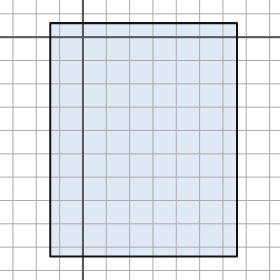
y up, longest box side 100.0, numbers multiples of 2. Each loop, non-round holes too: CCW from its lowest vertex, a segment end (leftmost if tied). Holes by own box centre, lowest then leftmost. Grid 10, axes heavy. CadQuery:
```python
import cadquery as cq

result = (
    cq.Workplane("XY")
    .moveTo(-14.0, -94.0)
    .lineTo(66.0, -94.0)
    .lineTo(66.0, 6.0)
    .lineTo(-14.0, 6.0)
    .close()
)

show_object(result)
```